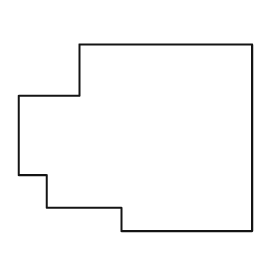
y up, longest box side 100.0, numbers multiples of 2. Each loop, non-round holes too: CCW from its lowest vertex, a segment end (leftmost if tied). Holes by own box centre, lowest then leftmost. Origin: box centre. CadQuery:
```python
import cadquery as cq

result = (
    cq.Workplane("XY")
    .moveTo(-6.0, -40.0)
    .lineTo(50.0, -40.0)
    .lineTo(50.0, 40.0)
    .lineTo(-24.0, 40.0)
    .lineTo(-24.0, 18.0)
    .lineTo(-50.0, 18.0)
    .lineTo(-50.0, -16.0)
    .lineTo(-38.0, -16.0)
    .lineTo(-38.0, -30.0)
    .lineTo(-6.0, -30.0)
    .close()
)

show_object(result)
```